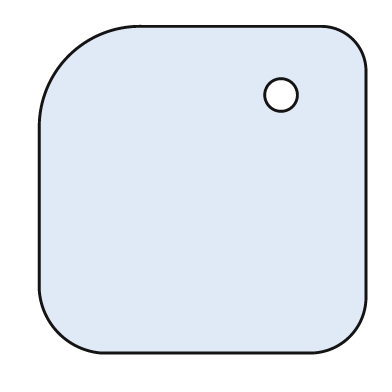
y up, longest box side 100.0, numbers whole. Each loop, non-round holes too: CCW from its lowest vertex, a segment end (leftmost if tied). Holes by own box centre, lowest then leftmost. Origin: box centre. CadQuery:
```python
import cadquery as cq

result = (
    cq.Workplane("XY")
    .moveTo(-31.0, -50.0)
    .lineTo(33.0, -50.0)
    .threePointArc((45.0, -45.0), (50.0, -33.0))
    .lineTo(50.0, 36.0)
    .threePointArc((46.0, 46.0), (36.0, 50.0))
    .lineTo(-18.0, 50.0)
    .threePointArc((-41.0, 41.0), (-50.0, 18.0))
    .lineTo(-50.0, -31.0)
    .threePointArc((-44.0, -44.0), (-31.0, -50.0))
    .close()
    .moveTo(24.0, 29.0)
    .circle(5.0)
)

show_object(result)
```